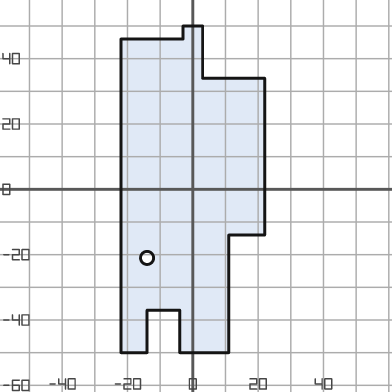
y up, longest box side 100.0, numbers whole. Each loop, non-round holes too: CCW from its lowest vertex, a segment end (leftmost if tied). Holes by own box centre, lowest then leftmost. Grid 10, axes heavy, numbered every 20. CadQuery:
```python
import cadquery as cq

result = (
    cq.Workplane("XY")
    .moveTo(-22.0, -50.0)
    .lineTo(-14.0, -50.0)
    .lineTo(-14.0, -37.0)
    .lineTo(-4.0, -37.0)
    .lineTo(-4.0, -50.0)
    .lineTo(11.0, -50.0)
    .lineTo(11.0, -14.0)
    .lineTo(22.0, -14.0)
    .lineTo(22.0, 34.0)
    .lineTo(3.0, 34.0)
    .lineTo(3.0, 50.0)
    .lineTo(-3.0, 50.0)
    .lineTo(-3.0, 46.0)
    .lineTo(-22.0, 46.0)
    .close()
    .moveTo(-14.0, -21.0)
    .circle(2.0)
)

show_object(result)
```